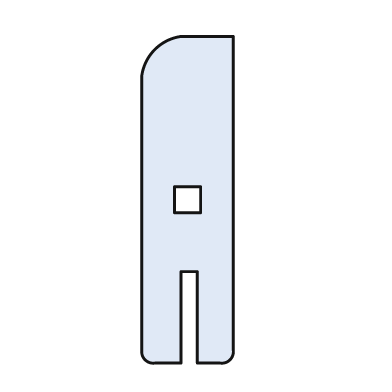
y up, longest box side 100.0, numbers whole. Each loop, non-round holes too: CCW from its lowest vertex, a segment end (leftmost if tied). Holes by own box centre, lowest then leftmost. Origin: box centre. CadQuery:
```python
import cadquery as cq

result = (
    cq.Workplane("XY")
    .moveTo(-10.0, -50.0)
    .lineTo(-2.0, -50.0)
    .lineTo(-2.0, -22.0)
    .lineTo(3.0, -22.0)
    .lineTo(3.0, -50.0)
    .lineTo(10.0, -50.0)
    .threePointArc((13.0, -49.0), (14.0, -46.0))
    .lineTo(14.0, 50.0)
    .lineTo(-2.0, 50.0)
    .threePointArc((-10.0, 46.0), (-14.0, 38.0))
    .lineTo(-14.0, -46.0)
    .threePointArc((-13.0, -49.0), (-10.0, -50.0))
    .close()
    .moveTo(-4.0, -4.0)
    .lineTo(4.0, -4.0)
    .lineTo(4.0, 4.0)
    .lineTo(-4.0, 4.0)
    .close()
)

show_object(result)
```